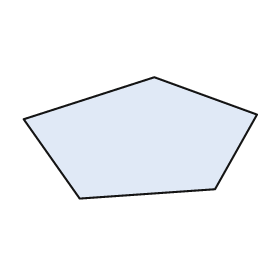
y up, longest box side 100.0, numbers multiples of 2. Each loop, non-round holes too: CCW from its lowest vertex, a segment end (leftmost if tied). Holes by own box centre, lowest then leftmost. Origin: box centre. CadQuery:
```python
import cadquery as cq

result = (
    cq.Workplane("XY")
    .moveTo(-26.0, -26.0)
    .lineTo(32.0, -22.0)
    .lineTo(50.0, 10.0)
    .lineTo(6.0, 26.0)
    .lineTo(-50.0, 8.0)
    .close()
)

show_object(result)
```